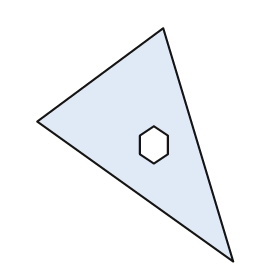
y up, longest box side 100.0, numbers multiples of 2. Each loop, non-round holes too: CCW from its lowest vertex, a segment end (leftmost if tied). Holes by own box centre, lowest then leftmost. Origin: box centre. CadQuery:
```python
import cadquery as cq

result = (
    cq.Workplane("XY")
    .moveTo(42.0, -50.0)
    .lineTo(12.0, 50.0)
    .lineTo(-42.0, 10.0)
    .close()
    .moveTo(8.0, -8.0)
    .lineTo(14.0, -4.0)
    .lineTo(14.0, 4.0)
    .lineTo(8.0, 8.0)
    .lineTo(2.0, 4.0)
    .lineTo(2.0, -4.0)
    .close()
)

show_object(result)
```